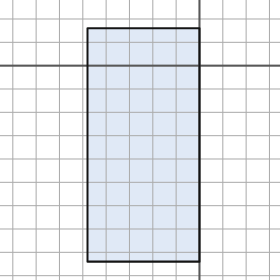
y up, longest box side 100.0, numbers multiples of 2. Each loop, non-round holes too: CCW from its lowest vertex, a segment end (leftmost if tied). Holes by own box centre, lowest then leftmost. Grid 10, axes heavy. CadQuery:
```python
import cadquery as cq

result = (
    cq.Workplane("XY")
    .moveTo(-48.0, -84.0)
    .lineTo(0.0, -84.0)
    .lineTo(0.0, 16.0)
    .lineTo(-48.0, 16.0)
    .close()
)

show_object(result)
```